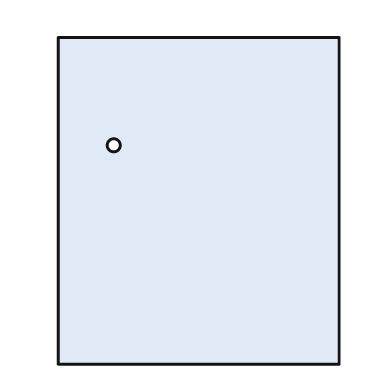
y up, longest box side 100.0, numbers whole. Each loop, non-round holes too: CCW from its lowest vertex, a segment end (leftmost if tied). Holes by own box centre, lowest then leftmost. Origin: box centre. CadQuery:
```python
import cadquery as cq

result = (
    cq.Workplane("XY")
    .moveTo(-43.0, -50.0)
    .lineTo(43.0, -50.0)
    .lineTo(43.0, 50.0)
    .lineTo(-43.0, 50.0)
    .close()
    .moveTo(-26.0, 17.0)
    .circle(2.0)
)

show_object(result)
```